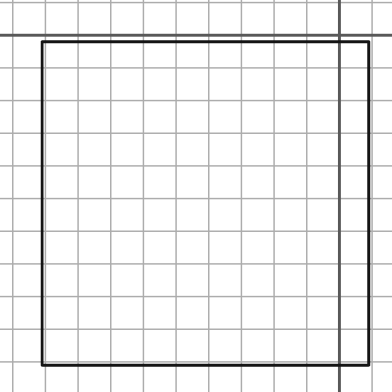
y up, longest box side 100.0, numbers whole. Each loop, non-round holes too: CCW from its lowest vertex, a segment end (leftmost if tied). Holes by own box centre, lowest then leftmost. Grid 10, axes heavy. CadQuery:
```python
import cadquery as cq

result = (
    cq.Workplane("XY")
    .moveTo(-91.0, -101.0)
    .lineTo(9.0, -101.0)
    .lineTo(9.0, -2.0)
    .lineTo(-91.0, -2.0)
    .close()
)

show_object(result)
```